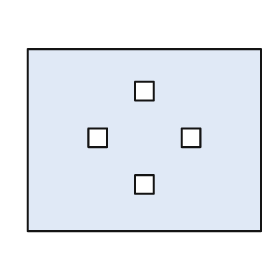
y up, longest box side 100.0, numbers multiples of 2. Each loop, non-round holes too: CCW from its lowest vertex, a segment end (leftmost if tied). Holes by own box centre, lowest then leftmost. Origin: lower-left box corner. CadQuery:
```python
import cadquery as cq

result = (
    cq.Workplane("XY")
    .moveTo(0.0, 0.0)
    .lineTo(100.0, 0.0)
    .lineTo(100.0, 78.0)
    .lineTo(0.0, 78.0)
    .close()
    .moveTo(46.0, 16.0)
    .lineTo(54.0, 16.0)
    .lineTo(54.0, 24.0)
    .lineTo(46.0, 24.0)
    .close()
    .moveTo(26.0, 36.0)
    .lineTo(34.0, 36.0)
    .lineTo(34.0, 44.0)
    .lineTo(26.0, 44.0)
    .close()
    .moveTo(66.0, 36.0)
    .lineTo(74.0, 36.0)
    .lineTo(74.0, 44.0)
    .lineTo(66.0, 44.0)
    .close()
    .moveTo(46.0, 56.0)
    .lineTo(54.0, 56.0)
    .lineTo(54.0, 64.0)
    .lineTo(46.0, 64.0)
    .close()
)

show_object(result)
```